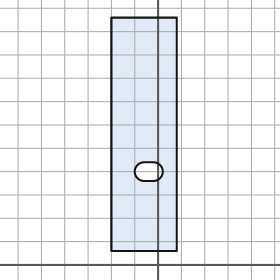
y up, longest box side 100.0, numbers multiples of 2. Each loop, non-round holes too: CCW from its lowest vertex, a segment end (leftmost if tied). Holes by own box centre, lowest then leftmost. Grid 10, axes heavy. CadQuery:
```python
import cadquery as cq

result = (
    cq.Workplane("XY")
    .moveTo(-20.0, 6.0)
    .lineTo(8.0, 6.0)
    .lineTo(8.0, 106.0)
    .lineTo(-20.0, 106.0)
    .close()
    .moveTo(-6.0, 36.0)
    .lineTo(-2.0, 36.0)
    .threePointArc((2.0, 40.0), (-2.0, 44.0))
    .lineTo(-6.0, 44.0)
    .threePointArc((-10.0, 40.0), (-6.0, 36.0))
    .close()
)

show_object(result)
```